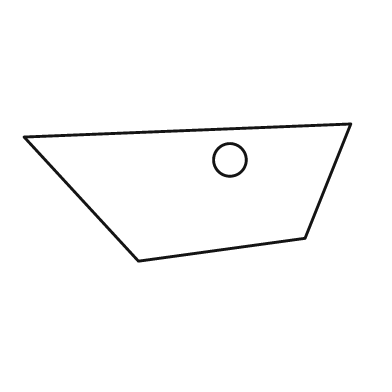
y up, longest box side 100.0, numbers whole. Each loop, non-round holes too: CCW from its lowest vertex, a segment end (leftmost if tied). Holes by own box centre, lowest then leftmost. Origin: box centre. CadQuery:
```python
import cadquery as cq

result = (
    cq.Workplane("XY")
    .moveTo(-15.0, -21.0)
    .lineTo(36.0, -14.0)
    .lineTo(50.0, 21.0)
    .lineTo(-50.0, 17.0)
    .close()
    .moveTo(13.0, 10.0)
    .circle(5.0)
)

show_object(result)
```